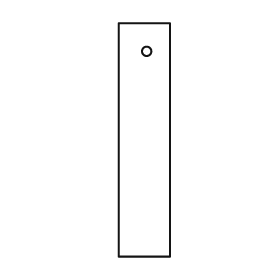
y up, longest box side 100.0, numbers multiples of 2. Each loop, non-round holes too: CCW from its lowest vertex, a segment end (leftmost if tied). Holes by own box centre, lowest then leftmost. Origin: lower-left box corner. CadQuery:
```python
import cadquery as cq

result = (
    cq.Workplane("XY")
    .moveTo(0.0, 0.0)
    .lineTo(22.0, 0.0)
    .lineTo(22.0, 100.0)
    .lineTo(0.0, 100.0)
    .close()
    .moveTo(12.0, 88.0)
    .circle(2.0)
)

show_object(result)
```